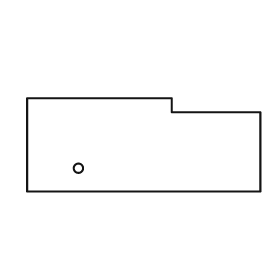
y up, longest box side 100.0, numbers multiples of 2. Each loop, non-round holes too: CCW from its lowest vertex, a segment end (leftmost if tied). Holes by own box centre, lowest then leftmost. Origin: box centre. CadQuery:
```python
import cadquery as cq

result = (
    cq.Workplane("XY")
    .moveTo(-50.0, -20.0)
    .lineTo(50.0, -20.0)
    .lineTo(50.0, 14.0)
    .lineTo(12.0, 14.0)
    .lineTo(12.0, 20.0)
    .lineTo(-50.0, 20.0)
    .close()
    .moveTo(-28.0, -10.0)
    .circle(2.0)
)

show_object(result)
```